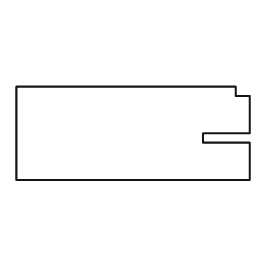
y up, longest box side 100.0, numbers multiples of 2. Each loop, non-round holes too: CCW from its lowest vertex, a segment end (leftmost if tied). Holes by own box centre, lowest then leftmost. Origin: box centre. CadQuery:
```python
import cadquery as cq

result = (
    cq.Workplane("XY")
    .moveTo(-50.0, -20.0)
    .lineTo(50.0, -20.0)
    .lineTo(50.0, -4.0)
    .lineTo(30.0, -4.0)
    .lineTo(30.0, 0.0)
    .lineTo(50.0, 0.0)
    .lineTo(50.0, 16.0)
    .lineTo(44.0, 16.0)
    .lineTo(44.0, 20.0)
    .lineTo(-50.0, 20.0)
    .close()
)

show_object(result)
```